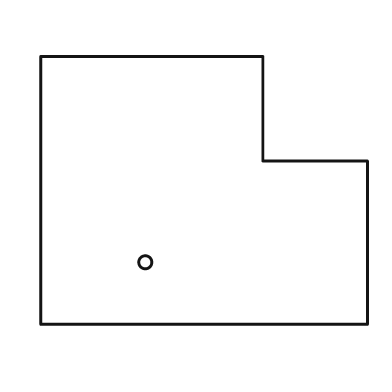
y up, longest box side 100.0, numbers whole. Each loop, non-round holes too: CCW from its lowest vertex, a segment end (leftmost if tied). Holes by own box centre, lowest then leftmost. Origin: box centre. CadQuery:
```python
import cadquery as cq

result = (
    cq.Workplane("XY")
    .moveTo(-50.0, -41.0)
    .lineTo(50.0, -41.0)
    .lineTo(50.0, 9.0)
    .lineTo(18.0, 9.0)
    .lineTo(18.0, 41.0)
    .lineTo(-50.0, 41.0)
    .close()
    .moveTo(-18.0, -22.0)
    .circle(2.0)
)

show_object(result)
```